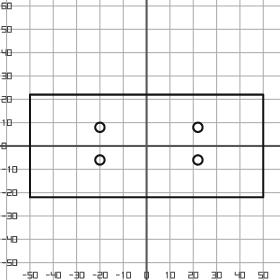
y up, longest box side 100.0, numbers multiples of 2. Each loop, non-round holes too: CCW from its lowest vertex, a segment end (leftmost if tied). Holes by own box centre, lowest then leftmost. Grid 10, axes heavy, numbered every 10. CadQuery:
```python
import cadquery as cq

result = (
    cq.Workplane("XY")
    .moveTo(-50.0, -22.0)
    .lineTo(50.0, -22.0)
    .lineTo(50.0, 22.0)
    .lineTo(-50.0, 22.0)
    .close()
    .moveTo(-20.0, -6.0)
    .circle(2.0)
    .moveTo(22.0, -6.0)
    .circle(2.0)
    .moveTo(-20.0, 8.0)
    .circle(2.0)
    .moveTo(22.0, 8.0)
    .circle(2.0)
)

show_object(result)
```